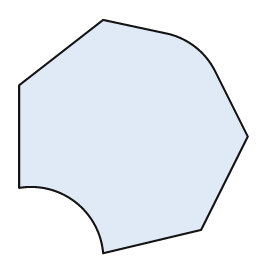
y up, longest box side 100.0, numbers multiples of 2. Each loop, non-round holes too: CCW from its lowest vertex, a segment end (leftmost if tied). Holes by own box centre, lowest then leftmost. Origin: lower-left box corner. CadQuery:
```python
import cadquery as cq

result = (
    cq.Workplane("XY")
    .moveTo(36.0, 0.0)
    .lineTo(78.0, 10.0)
    .lineTo(98.0, 50.0)
    .lineTo(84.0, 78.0)
    .threePointArc((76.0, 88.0), (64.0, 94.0))
    .lineTo(36.0, 100.0)
    .lineTo(0.0, 72.0)
    .lineTo(0.0, 28.0)
    .threePointArc((24.0, 22.0), (36.0, 0.0))
    .close()
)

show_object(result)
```